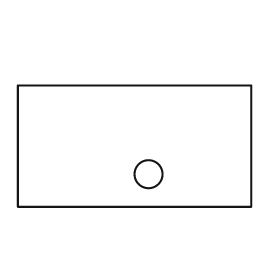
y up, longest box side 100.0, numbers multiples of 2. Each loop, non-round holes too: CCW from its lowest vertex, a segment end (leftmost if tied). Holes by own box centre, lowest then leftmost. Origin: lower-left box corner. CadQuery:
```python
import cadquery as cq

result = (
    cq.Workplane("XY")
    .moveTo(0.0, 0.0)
    .lineTo(100.0, 0.0)
    .lineTo(100.0, 52.0)
    .lineTo(0.0, 52.0)
    .close()
    .moveTo(56.0, 14.0)
    .circle(6.0)
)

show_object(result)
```